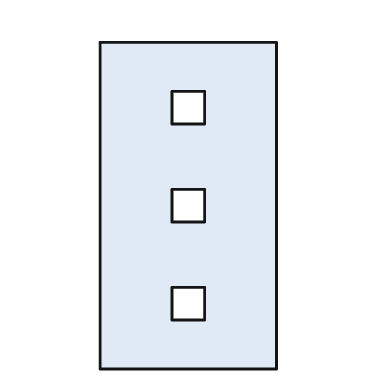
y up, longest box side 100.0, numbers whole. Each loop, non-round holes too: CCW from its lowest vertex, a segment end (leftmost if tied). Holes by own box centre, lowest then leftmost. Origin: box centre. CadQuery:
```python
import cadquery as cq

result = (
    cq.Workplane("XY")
    .moveTo(-27.0, -50.0)
    .lineTo(27.0, -50.0)
    .lineTo(27.0, 50.0)
    .lineTo(-27.0, 50.0)
    .close()
    .moveTo(-5.0, -35.0)
    .lineTo(5.0, -35.0)
    .lineTo(5.0, -25.0)
    .lineTo(-5.0, -25.0)
    .close()
    .moveTo(-5.0, -5.0)
    .lineTo(5.0, -5.0)
    .lineTo(5.0, 5.0)
    .lineTo(-5.0, 5.0)
    .close()
    .moveTo(-5.0, 25.0)
    .lineTo(5.0, 25.0)
    .lineTo(5.0, 35.0)
    .lineTo(-5.0, 35.0)
    .close()
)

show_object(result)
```